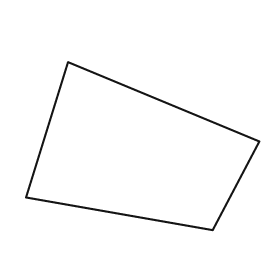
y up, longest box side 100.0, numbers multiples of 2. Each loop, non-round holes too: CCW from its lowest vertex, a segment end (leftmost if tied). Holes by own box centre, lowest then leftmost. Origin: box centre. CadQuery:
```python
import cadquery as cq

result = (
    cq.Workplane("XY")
    .moveTo(30.0, -36.0)
    .lineTo(50.0, 2.0)
    .lineTo(-32.0, 36.0)
    .lineTo(-50.0, -22.0)
    .close()
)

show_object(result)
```